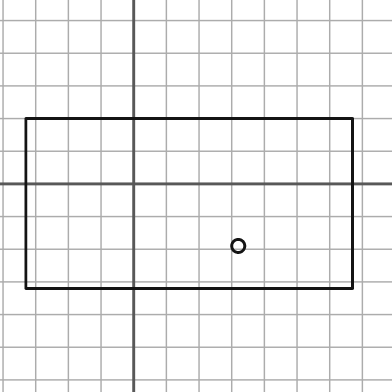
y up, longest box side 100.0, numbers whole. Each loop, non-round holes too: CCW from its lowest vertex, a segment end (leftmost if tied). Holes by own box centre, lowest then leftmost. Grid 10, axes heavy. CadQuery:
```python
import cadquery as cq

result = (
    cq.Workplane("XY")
    .moveTo(-33.0, -32.0)
    .lineTo(67.0, -32.0)
    .lineTo(67.0, 20.0)
    .lineTo(-33.0, 20.0)
    .close()
    .moveTo(32.0, -19.0)
    .circle(2.0)
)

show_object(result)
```